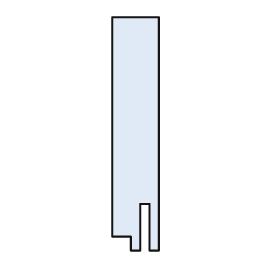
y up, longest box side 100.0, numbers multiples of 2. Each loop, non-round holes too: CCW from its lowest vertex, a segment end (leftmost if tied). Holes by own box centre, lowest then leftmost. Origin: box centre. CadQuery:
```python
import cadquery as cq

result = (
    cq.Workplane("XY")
    .moveTo(-2.0, -50.0)
    .lineTo(2.0, -50.0)
    .lineTo(2.0, -30.0)
    .lineTo(6.0, -30.0)
    .lineTo(6.0, -50.0)
    .lineTo(10.0, -50.0)
    .lineTo(10.0, 50.0)
    .lineTo(-10.0, 50.0)
    .lineTo(-10.0, -44.0)
    .lineTo(-2.0, -44.0)
    .close()
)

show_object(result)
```